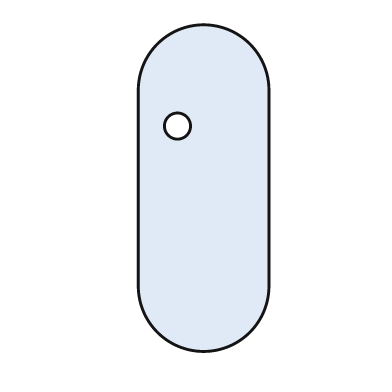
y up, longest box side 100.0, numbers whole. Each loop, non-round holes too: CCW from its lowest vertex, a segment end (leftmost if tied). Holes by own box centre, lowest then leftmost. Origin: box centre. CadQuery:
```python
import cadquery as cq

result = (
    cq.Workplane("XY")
    .moveTo(-20.0, -30.0)
    .threePointArc((0.0, -50.0), (20.0, -30.0))
    .lineTo(20.0, 30.0)
    .threePointArc((0.0, 50.0), (-20.0, 30.0))
    .close()
    .moveTo(-8.0, 19.0)
    .circle(4.0)
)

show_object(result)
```